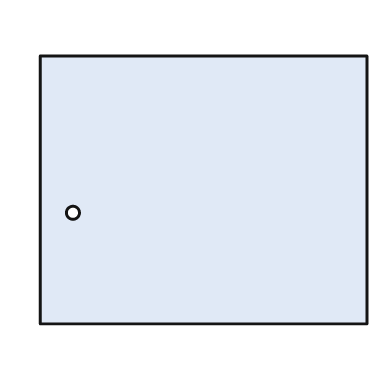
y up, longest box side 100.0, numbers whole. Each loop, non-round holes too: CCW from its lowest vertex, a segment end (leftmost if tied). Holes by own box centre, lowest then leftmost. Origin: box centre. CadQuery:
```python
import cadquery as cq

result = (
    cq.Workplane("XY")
    .moveTo(-50.0, -41.0)
    .lineTo(50.0, -41.0)
    .lineTo(50.0, 41.0)
    .lineTo(-50.0, 41.0)
    .close()
    .moveTo(-40.0, -7.0)
    .circle(2.0)
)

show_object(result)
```